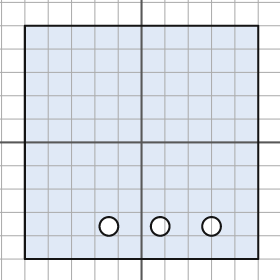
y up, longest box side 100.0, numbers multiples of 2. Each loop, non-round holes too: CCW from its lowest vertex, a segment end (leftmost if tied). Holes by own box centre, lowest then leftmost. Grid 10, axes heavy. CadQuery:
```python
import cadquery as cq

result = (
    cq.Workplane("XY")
    .moveTo(-50.0, -50.0)
    .lineTo(50.0, -50.0)
    .lineTo(50.0, 50.0)
    .lineTo(-50.0, 50.0)
    .close()
    .moveTo(-14.0, -36.0)
    .circle(4.0)
    .moveTo(8.0, -36.0)
    .circle(4.0)
    .moveTo(30.0, -36.0)
    .circle(4.0)
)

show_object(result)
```